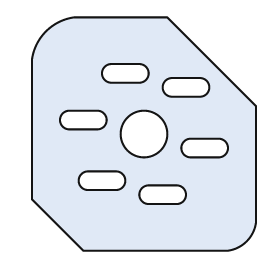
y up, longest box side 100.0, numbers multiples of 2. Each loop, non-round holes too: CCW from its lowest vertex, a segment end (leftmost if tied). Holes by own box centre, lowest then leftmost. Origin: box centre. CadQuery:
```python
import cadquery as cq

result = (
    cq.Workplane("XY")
    .moveTo(-26.0, -50.0)
    .lineTo(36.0, -50.0)
    .threePointArc((44.0, -46.0), (48.0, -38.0))
    .lineTo(48.0, 12.0)
    .lineTo(10.0, 50.0)
    .lineTo(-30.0, 50.0)
    .threePointArc((-42.0, 44.0), (-48.0, 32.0))
    .lineTo(-48.0, -28.0)
    .close()
    .moveTo(2.0, -30.0)
    .lineTo(14.0, -30.0)
    .threePointArc((18.0, -26.0), (14.0, -22.0))
    .lineTo(2.0, -22.0)
    .threePointArc((-2.0, -26.0), (2.0, -30.0))
    .close()
    .moveTo(-24.0, -24.0)
    .lineTo(-12.0, -24.0)
    .threePointArc((-8.0, -20.0), (-12.0, -16.0))
    .lineTo(-24.0, -16.0)
    .threePointArc((-28.0, -20.0), (-24.0, -24.0))
    .close()
    .moveTo(20.0, -10.0)
    .lineTo(32.0, -10.0)
    .threePointArc((36.0, -6.0), (32.0, -2.0))
    .lineTo(20.0, -2.0)
    .threePointArc((16.0, -6.0), (20.0, -10.0))
    .close()
    .moveTo(0.0, 0.0)
    .circle(10.0)
    .moveTo(-32.0, 2.0)
    .lineTo(-20.0, 2.0)
    .threePointArc((-16.0, 6.0), (-20.0, 10.0))
    .lineTo(-32.0, 10.0)
    .threePointArc((-36.0, 6.0), (-32.0, 2.0))
    .close()
    .moveTo(12.0, 16.0)
    .lineTo(24.0, 16.0)
    .threePointArc((28.0, 20.0), (24.0, 24.0))
    .lineTo(12.0, 24.0)
    .threePointArc((8.0, 20.0), (12.0, 16.0))
    .close()
    .moveTo(-14.0, 22.0)
    .lineTo(-2.0, 22.0)
    .threePointArc((2.0, 26.0), (-2.0, 30.0))
    .lineTo(-14.0, 30.0)
    .threePointArc((-18.0, 26.0), (-14.0, 22.0))
    .close()
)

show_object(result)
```